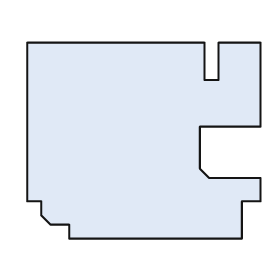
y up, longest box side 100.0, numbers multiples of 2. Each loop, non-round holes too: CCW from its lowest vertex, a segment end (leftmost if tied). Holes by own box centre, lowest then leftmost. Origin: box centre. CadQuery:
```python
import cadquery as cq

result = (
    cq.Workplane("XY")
    .moveTo(-32.0, -42.0)
    .lineTo(42.0, -42.0)
    .lineTo(42.0, -26.0)
    .lineTo(50.0, -26.0)
    .lineTo(50.0, -16.0)
    .lineTo(28.0, -16.0)
    .lineTo(24.0, -12.0)
    .lineTo(24.0, 6.0)
    .lineTo(50.0, 6.0)
    .lineTo(50.0, 42.0)
    .lineTo(32.0, 42.0)
    .lineTo(32.0, 26.0)
    .lineTo(26.0, 26.0)
    .lineTo(26.0, 42.0)
    .lineTo(-50.0, 42.0)
    .lineTo(-50.0, -26.0)
    .lineTo(-44.0, -26.0)
    .lineTo(-44.0, -32.0)
    .lineTo(-40.0, -36.0)
    .lineTo(-32.0, -36.0)
    .close()
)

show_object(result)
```